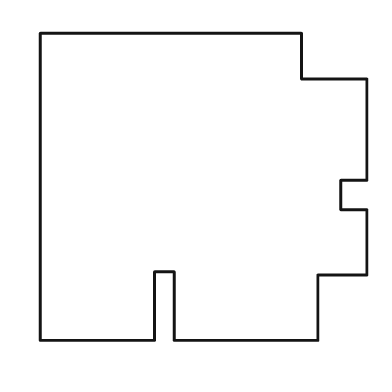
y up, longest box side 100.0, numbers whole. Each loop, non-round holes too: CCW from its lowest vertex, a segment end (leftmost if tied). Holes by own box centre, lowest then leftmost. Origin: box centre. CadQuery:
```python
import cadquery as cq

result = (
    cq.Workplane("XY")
    .moveTo(-50.0, -47.0)
    .lineTo(-15.0, -47.0)
    .lineTo(-15.0, -26.0)
    .lineTo(-9.0, -26.0)
    .lineTo(-9.0, -47.0)
    .lineTo(35.0, -47.0)
    .lineTo(35.0, -27.0)
    .lineTo(50.0, -27.0)
    .lineTo(50.0, -7.0)
    .lineTo(42.0, -7.0)
    .lineTo(42.0, 2.0)
    .lineTo(50.0, 2.0)
    .lineTo(50.0, 33.0)
    .lineTo(30.0, 33.0)
    .lineTo(30.0, 47.0)
    .lineTo(-50.0, 47.0)
    .close()
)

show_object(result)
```